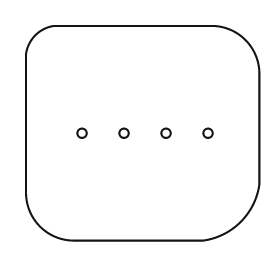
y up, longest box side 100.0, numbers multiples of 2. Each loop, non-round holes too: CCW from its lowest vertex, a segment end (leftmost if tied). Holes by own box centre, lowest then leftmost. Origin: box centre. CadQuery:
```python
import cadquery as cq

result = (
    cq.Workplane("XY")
    .moveTo(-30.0, -46.0)
    .lineTo(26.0, -46.0)
    .threePointArc((42.0, -38.0), (50.0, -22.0))
    .lineTo(50.0, 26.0)
    .threePointArc((44.0, 40.0), (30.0, 46.0))
    .lineTo(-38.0, 46.0)
    .threePointArc((-46.0, 42.0), (-50.0, 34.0))
    .lineTo(-50.0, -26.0)
    .threePointArc((-44.0, -40.0), (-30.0, -46.0))
    .close()
    .moveTo(-26.0, 0.0)
    .circle(2.0)
    .moveTo(-8.0, 0.0)
    .circle(2.0)
    .moveTo(10.0, 0.0)
    .circle(2.0)
    .moveTo(28.0, 0.0)
    .circle(2.0)
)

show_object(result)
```